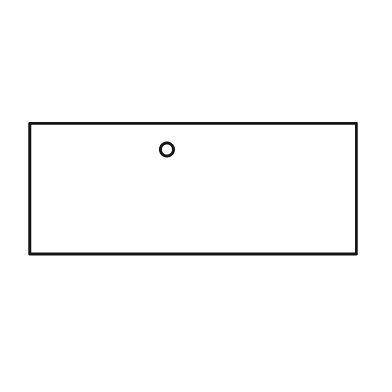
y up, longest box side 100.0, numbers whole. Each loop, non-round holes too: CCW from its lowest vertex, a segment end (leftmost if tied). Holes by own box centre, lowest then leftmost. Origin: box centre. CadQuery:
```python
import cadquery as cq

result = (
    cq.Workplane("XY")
    .moveTo(-50.0, -20.0)
    .lineTo(50.0, -20.0)
    .lineTo(50.0, 20.0)
    .lineTo(-50.0, 20.0)
    .close()
    .moveTo(-8.0, 12.0)
    .circle(2.0)
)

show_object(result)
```